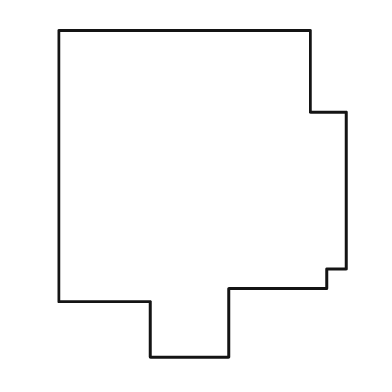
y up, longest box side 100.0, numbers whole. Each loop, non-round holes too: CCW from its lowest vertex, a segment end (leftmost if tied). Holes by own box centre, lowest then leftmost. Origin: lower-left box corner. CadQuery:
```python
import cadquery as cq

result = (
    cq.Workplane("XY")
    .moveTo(28.0, 0.0)
    .lineTo(52.0, 0.0)
    .lineTo(52.0, 21.0)
    .lineTo(82.0, 21.0)
    .lineTo(82.0, 27.0)
    .lineTo(88.0, 27.0)
    .lineTo(88.0, 75.0)
    .lineTo(77.0, 75.0)
    .lineTo(77.0, 100.0)
    .lineTo(0.0, 100.0)
    .lineTo(0.0, 17.0)
    .lineTo(28.0, 17.0)
    .close()
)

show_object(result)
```